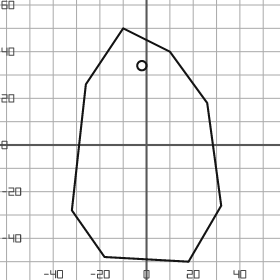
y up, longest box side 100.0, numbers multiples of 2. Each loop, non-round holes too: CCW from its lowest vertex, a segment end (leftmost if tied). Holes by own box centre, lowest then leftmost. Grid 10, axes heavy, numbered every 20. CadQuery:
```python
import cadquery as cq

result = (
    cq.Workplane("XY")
    .moveTo(18.0, -50.0)
    .lineTo(32.0, -26.0)
    .lineTo(26.0, 18.0)
    .lineTo(10.0, 40.0)
    .lineTo(-10.0, 50.0)
    .lineTo(-26.0, 26.0)
    .lineTo(-32.0, -28.0)
    .lineTo(-18.0, -48.0)
    .close()
    .moveTo(-2.0, 34.0)
    .circle(2.0)
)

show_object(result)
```